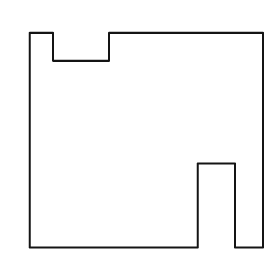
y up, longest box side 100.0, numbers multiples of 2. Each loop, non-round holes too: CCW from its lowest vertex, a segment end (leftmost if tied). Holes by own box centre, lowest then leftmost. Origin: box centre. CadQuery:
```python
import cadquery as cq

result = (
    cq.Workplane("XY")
    .moveTo(-50.0, -46.0)
    .lineTo(22.0, -46.0)
    .lineTo(22.0, -10.0)
    .lineTo(38.0, -10.0)
    .lineTo(38.0, -46.0)
    .lineTo(50.0, -46.0)
    .lineTo(50.0, 46.0)
    .lineTo(-16.0, 46.0)
    .lineTo(-16.0, 34.0)
    .lineTo(-40.0, 34.0)
    .lineTo(-40.0, 46.0)
    .lineTo(-50.0, 46.0)
    .close()
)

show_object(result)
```